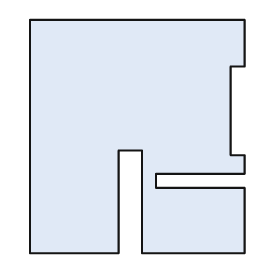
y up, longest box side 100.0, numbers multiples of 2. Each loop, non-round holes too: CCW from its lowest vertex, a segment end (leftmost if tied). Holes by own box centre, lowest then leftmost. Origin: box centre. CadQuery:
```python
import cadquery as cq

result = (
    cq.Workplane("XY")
    .moveTo(-46.0, -50.0)
    .lineTo(-8.0, -50.0)
    .lineTo(-8.0, -6.0)
    .lineTo(2.0, -6.0)
    .lineTo(2.0, -50.0)
    .lineTo(46.0, -50.0)
    .lineTo(46.0, -22.0)
    .lineTo(8.0, -22.0)
    .lineTo(8.0, -16.0)
    .lineTo(46.0, -16.0)
    .lineTo(46.0, -8.0)
    .lineTo(40.0, -8.0)
    .lineTo(40.0, 30.0)
    .lineTo(46.0, 30.0)
    .lineTo(46.0, 50.0)
    .lineTo(-46.0, 50.0)
    .close()
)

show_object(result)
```